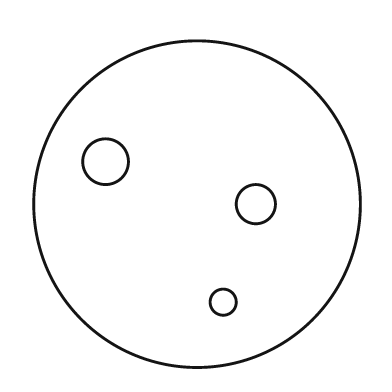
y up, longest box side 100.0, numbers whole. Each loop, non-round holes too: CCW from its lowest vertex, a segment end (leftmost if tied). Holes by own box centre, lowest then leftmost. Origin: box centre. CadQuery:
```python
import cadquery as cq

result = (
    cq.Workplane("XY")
    .moveTo(0.0, 0.0)
    .circle(50.0)
    .moveTo(8.0, -30.0)
    .circle(4.0)
    .moveTo(18.0, 0.0)
    .circle(6.0)
    .moveTo(-28.0, 13.0)
    .circle(7.0)
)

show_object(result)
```